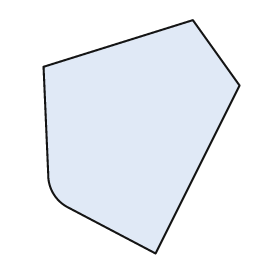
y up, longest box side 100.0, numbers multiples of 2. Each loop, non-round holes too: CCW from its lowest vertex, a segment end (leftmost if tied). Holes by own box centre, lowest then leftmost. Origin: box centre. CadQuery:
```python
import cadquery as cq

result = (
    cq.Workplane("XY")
    .moveTo(6.0, -50.0)
    .lineTo(42.0, 22.0)
    .lineTo(22.0, 50.0)
    .lineTo(-42.0, 30.0)
    .lineTo(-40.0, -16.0)
    .threePointArc((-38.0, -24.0), (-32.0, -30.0))
    .close()
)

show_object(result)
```